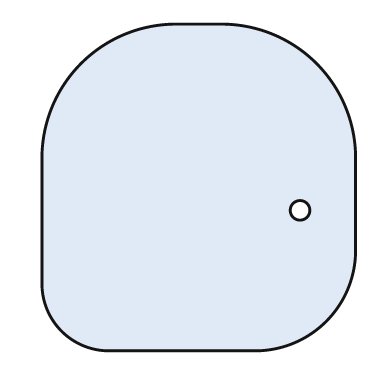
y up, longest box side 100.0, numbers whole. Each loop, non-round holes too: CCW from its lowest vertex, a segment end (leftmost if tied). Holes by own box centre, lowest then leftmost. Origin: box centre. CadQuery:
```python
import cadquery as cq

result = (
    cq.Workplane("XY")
    .moveTo(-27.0, -50.0)
    .lineTo(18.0, -50.0)
    .threePointArc((39.0, -41.0), (48.0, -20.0))
    .lineTo(48.0, 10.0)
    .threePointArc((36.0, 38.0), (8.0, 50.0))
    .lineTo(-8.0, 50.0)
    .threePointArc((-36.0, 38.0), (-48.0, 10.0))
    .lineTo(-48.0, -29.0)
    .threePointArc((-42.0, -44.0), (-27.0, -50.0))
    .close()
    .moveTo(31.0, -7.0)
    .circle(3.0)
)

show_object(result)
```